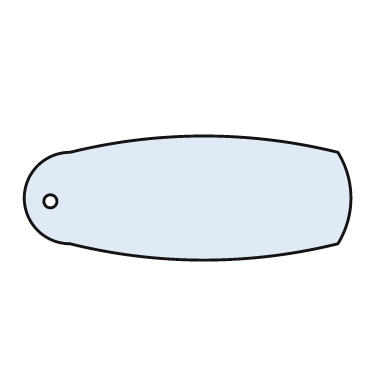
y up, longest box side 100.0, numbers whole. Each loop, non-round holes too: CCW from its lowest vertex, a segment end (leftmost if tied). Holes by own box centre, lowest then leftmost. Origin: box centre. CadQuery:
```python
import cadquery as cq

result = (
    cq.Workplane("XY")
    .moveTo(-36.0, -14.0)
    .threePointArc((5.0, -19.0), (46.0, -14.0))
    .threePointArc((50.0, 0.0), (46.0, 14.0))
    .threePointArc((5.0, 19.0), (-36.0, 14.0))
    .threePointArc((-50.0, 0.0), (-36.0, -14.0))
    .close()
    .moveTo(-42.0, -1.0)
    .circle(2.0)
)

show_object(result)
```